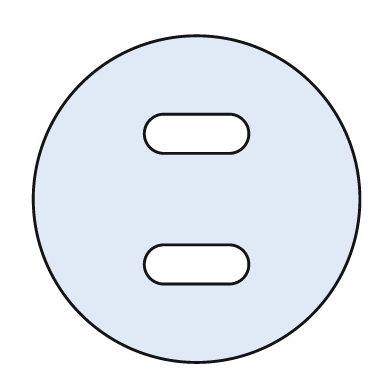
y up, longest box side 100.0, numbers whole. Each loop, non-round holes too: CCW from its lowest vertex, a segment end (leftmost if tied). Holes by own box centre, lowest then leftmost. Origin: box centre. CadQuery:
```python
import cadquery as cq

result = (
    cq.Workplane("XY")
    .moveTo(0.0, 0.0)
    .circle(50.0)
    .moveTo(-10.0, -26.0)
    .lineTo(10.0, -26.0)
    .threePointArc((16.0, -20.0), (10.0, -14.0))
    .lineTo(-10.0, -14.0)
    .threePointArc((-16.0, -20.0), (-10.0, -26.0))
    .close()
    .moveTo(-10.0, 14.0)
    .lineTo(10.0, 14.0)
    .threePointArc((16.0, 20.0), (10.0, 26.0))
    .lineTo(-10.0, 26.0)
    .threePointArc((-16.0, 20.0), (-10.0, 14.0))
    .close()
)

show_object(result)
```